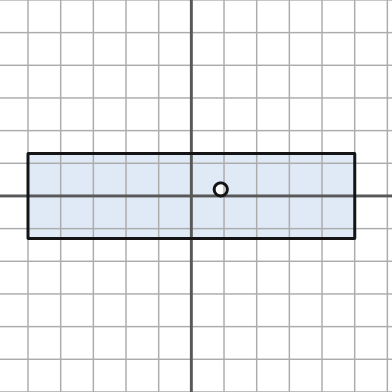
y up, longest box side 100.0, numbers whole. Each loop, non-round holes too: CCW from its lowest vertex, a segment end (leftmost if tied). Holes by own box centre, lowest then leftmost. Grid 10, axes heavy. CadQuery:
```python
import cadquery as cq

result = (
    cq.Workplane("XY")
    .moveTo(-50.0, -13.0)
    .lineTo(50.0, -13.0)
    .lineTo(50.0, 13.0)
    .lineTo(-50.0, 13.0)
    .close()
    .moveTo(9.0, 2.0)
    .circle(2.0)
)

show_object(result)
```